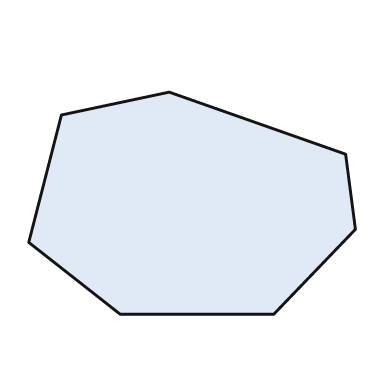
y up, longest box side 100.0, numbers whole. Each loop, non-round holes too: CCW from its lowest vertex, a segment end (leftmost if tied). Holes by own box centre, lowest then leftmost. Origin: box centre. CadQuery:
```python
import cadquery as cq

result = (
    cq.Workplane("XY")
    .moveTo(-22.0, -34.0)
    .lineTo(25.0, -34.0)
    .lineTo(50.0, -8.0)
    .lineTo(47.0, 15.0)
    .lineTo(-7.0, 34.0)
    .lineTo(-40.0, 27.0)
    .lineTo(-50.0, -12.0)
    .close()
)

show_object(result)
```